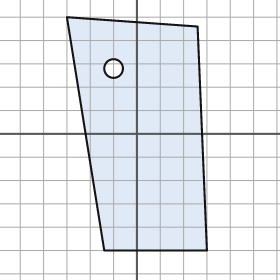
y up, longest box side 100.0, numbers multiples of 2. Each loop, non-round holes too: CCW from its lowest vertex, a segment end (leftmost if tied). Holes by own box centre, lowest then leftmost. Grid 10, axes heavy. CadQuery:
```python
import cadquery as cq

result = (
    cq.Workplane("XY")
    .moveTo(-14.0, -50.0)
    .lineTo(30.0, -50.0)
    .lineTo(26.0, 46.0)
    .lineTo(-30.0, 50.0)
    .close()
    .moveTo(-10.0, 28.0)
    .circle(4.0)
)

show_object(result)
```